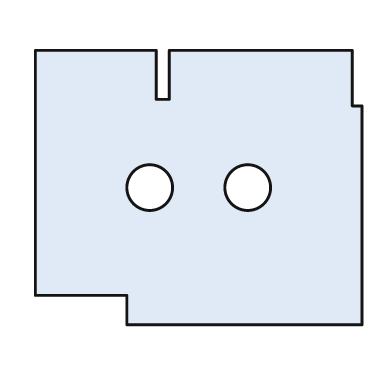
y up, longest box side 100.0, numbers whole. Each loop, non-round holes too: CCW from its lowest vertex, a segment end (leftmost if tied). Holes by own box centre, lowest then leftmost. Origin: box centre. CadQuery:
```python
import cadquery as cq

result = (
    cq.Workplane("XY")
    .moveTo(-22.0, -42.0)
    .lineTo(50.0, -42.0)
    .lineTo(50.0, 25.0)
    .lineTo(47.0, 25.0)
    .lineTo(47.0, 42.0)
    .lineTo(-9.0, 42.0)
    .lineTo(-9.0, 27.0)
    .lineTo(-13.0, 27.0)
    .lineTo(-13.0, 42.0)
    .lineTo(-50.0, 42.0)
    .lineTo(-50.0, -33.0)
    .lineTo(-22.0, -33.0)
    .close()
    .moveTo(-15.0, 0.0)
    .circle(7.0)
    .moveTo(15.0, 0.0)
    .circle(7.0)
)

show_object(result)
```